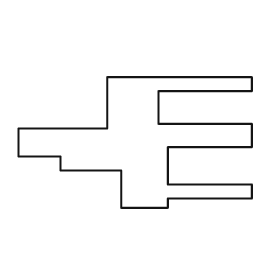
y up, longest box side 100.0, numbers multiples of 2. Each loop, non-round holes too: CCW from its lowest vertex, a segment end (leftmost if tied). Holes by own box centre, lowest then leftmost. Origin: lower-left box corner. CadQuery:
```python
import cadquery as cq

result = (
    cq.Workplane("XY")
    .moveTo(44.0, 0.0)
    .lineTo(64.0, 0.0)
    .lineTo(64.0, 4.0)
    .lineTo(100.0, 4.0)
    .lineTo(100.0, 10.0)
    .lineTo(64.0, 10.0)
    .lineTo(64.0, 26.0)
    .lineTo(100.0, 26.0)
    .lineTo(100.0, 36.0)
    .lineTo(60.0, 36.0)
    .lineTo(60.0, 50.0)
    .lineTo(100.0, 50.0)
    .lineTo(100.0, 56.0)
    .lineTo(38.0, 56.0)
    .lineTo(38.0, 34.0)
    .lineTo(0.0, 34.0)
    .lineTo(0.0, 22.0)
    .lineTo(18.0, 22.0)
    .lineTo(18.0, 16.0)
    .lineTo(44.0, 16.0)
    .close()
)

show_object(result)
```